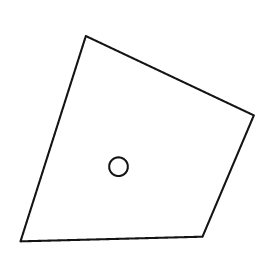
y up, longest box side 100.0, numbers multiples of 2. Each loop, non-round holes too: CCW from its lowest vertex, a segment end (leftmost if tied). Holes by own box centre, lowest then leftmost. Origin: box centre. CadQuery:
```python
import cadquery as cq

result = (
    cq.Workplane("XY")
    .moveTo(-50.0, -44.0)
    .lineTo(28.0, -42.0)
    .lineTo(50.0, 10.0)
    .lineTo(-22.0, 44.0)
    .close()
    .moveTo(-8.0, -12.0)
    .circle(4.0)
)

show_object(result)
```